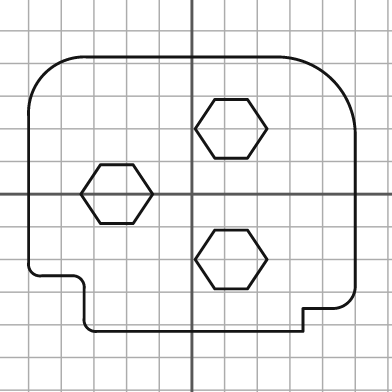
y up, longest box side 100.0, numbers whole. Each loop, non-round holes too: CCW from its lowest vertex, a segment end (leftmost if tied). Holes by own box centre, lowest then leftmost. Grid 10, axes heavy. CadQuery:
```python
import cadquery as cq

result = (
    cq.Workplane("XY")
    .moveTo(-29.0, -42.0)
    .lineTo(34.0, -42.0)
    .lineTo(34.0, -35.0)
    .lineTo(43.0, -35.0)
    .threePointArc((48.0, -33.0), (50.0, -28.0))
    .lineTo(50.0, 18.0)
    .threePointArc((43.0, 35.0), (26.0, 42.0))
    .lineTo(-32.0, 42.0)
    .threePointArc((-45.0, 37.0), (-50.0, 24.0))
    .lineTo(-50.0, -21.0)
    .threePointArc((-49.0, -24.0), (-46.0, -25.0))
    .lineTo(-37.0, -25.0)
    .threePointArc((-34.0, -26.0), (-33.0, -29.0))
    .lineTo(-33.0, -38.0)
    .threePointArc((-32.0, -41.0), (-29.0, -42.0))
    .close()
    .moveTo(7.0, -29.0)
    .lineTo(17.0, -29.0)
    .lineTo(23.0, -20.0)
    .lineTo(17.0, -11.0)
    .lineTo(7.0, -11.0)
    .lineTo(1.0, -20.0)
    .close()
    .moveTo(-28.0, -9.0)
    .lineTo(-18.0, -9.0)
    .lineTo(-12.0, 0.0)
    .lineTo(-18.0, 9.0)
    .lineTo(-28.0, 9.0)
    .lineTo(-34.0, 0.0)
    .close()
    .moveTo(7.0, 11.0)
    .lineTo(17.0, 11.0)
    .lineTo(23.0, 20.0)
    .lineTo(17.0, 29.0)
    .lineTo(7.0, 29.0)
    .lineTo(1.0, 20.0)
    .close()
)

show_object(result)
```